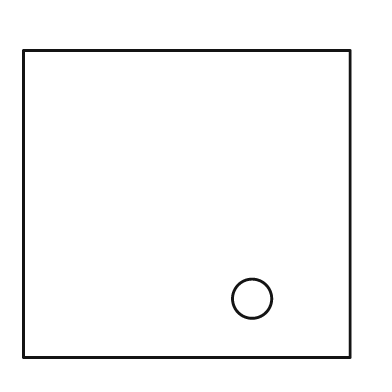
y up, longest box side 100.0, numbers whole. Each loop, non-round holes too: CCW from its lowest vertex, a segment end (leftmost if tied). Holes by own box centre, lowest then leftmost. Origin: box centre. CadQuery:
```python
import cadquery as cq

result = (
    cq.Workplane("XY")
    .moveTo(-50.0, -47.0)
    .lineTo(50.0, -47.0)
    .lineTo(50.0, 47.0)
    .lineTo(-50.0, 47.0)
    .close()
    .moveTo(20.0, -29.0)
    .circle(6.0)
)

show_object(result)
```